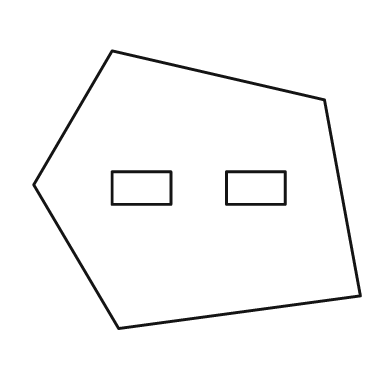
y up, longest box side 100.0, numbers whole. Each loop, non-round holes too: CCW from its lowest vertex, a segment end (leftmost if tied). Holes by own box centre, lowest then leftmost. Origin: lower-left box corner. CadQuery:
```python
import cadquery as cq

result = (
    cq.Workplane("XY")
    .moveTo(26.0, 0.0)
    .lineTo(100.0, 10.0)
    .lineTo(89.0, 70.0)
    .lineTo(24.0, 85.0)
    .lineTo(0.0, 44.0)
    .close()
    .moveTo(24.0, 38.0)
    .lineTo(42.0, 38.0)
    .lineTo(42.0, 48.0)
    .lineTo(24.0, 48.0)
    .close()
    .moveTo(59.0, 38.0)
    .lineTo(77.0, 38.0)
    .lineTo(77.0, 48.0)
    .lineTo(59.0, 48.0)
    .close()
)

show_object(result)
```